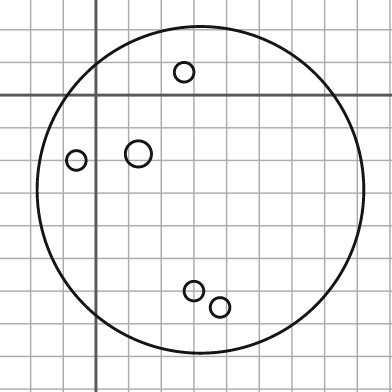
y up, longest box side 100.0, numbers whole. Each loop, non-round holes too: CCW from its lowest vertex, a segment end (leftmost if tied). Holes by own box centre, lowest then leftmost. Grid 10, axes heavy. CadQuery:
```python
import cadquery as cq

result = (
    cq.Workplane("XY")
    .moveTo(32.0, -29.0)
    .circle(50.0)
    .moveTo(38.0, -65.0)
    .circle(3.0)
    .moveTo(30.0, -60.0)
    .circle(3.0)
    .moveTo(-6.0, -20.0)
    .circle(3.0)
    .moveTo(13.0, -18.0)
    .circle(4.0)
    .moveTo(27.0, 7.0)
    .circle(3.0)
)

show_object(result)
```